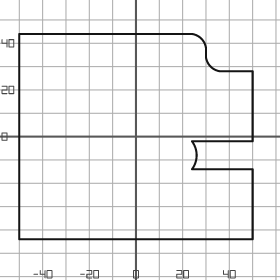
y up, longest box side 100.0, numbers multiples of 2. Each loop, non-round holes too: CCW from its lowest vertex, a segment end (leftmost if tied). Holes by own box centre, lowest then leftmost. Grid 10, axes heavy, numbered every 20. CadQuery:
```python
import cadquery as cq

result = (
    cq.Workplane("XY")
    .moveTo(-50.0, -44.0)
    .lineTo(50.0, -44.0)
    .lineTo(50.0, -14.0)
    .lineTo(24.0, -14.0)
    .threePointArc((26.0, -8.0), (24.0, -2.0))
    .lineTo(50.0, -2.0)
    .lineTo(50.0, 28.0)
    .lineTo(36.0, 28.0)
    .threePointArc((32.0, 30.0), (30.0, 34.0))
    .lineTo(30.0, 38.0)
    .threePointArc((28.0, 42.0), (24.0, 44.0))
    .lineTo(-50.0, 44.0)
    .close()
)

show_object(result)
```